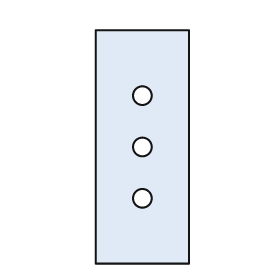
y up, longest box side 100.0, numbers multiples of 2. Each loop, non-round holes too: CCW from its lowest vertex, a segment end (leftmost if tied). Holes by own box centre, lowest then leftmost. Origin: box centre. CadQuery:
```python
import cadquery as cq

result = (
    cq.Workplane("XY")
    .moveTo(-20.0, -50.0)
    .lineTo(20.0, -50.0)
    .lineTo(20.0, 50.0)
    .lineTo(-20.0, 50.0)
    .close()
    .moveTo(0.0, -22.0)
    .circle(4.0)
    .moveTo(0.0, 0.0)
    .circle(4.0)
    .moveTo(0.0, 22.0)
    .circle(4.0)
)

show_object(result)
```